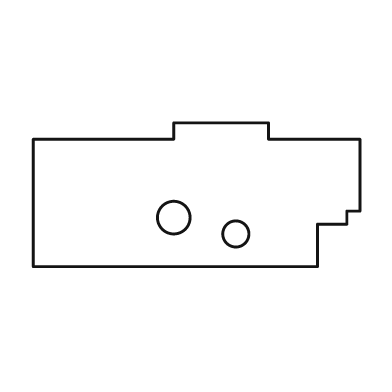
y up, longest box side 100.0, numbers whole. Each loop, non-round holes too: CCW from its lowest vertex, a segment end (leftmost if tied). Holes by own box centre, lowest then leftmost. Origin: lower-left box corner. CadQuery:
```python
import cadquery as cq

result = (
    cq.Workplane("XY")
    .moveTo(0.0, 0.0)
    .lineTo(87.0, 0.0)
    .lineTo(87.0, 13.0)
    .lineTo(96.0, 13.0)
    .lineTo(96.0, 17.0)
    .lineTo(100.0, 17.0)
    .lineTo(100.0, 39.0)
    .lineTo(72.0, 39.0)
    .lineTo(72.0, 44.0)
    .lineTo(43.0, 44.0)
    .lineTo(43.0, 39.0)
    .lineTo(0.0, 39.0)
    .close()
    .moveTo(62.0, 10.0)
    .circle(4.0)
    .moveTo(43.0, 15.0)
    .circle(5.0)
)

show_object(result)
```